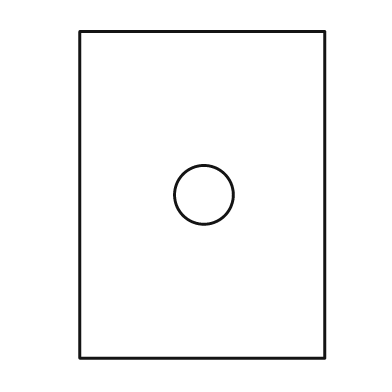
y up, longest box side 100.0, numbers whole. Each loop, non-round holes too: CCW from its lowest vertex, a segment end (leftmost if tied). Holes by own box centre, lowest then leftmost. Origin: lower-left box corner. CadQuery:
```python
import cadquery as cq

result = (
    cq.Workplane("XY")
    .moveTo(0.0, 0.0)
    .lineTo(75.0, 0.0)
    .lineTo(75.0, 100.0)
    .lineTo(0.0, 100.0)
    .close()
    .moveTo(38.0, 50.0)
    .circle(9.0)
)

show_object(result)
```